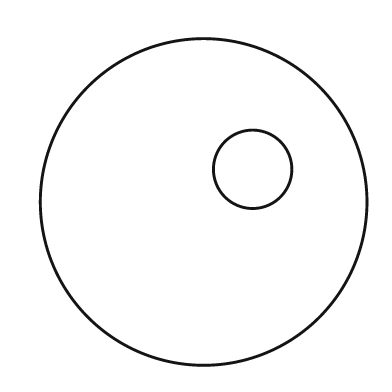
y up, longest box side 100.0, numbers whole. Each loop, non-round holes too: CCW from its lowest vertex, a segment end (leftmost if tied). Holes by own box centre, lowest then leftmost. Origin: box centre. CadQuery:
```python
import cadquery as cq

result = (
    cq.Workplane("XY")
    .moveTo(0.0, 0.0)
    .circle(50.0)
    .moveTo(15.0, 10.0)
    .circle(12.0)
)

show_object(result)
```